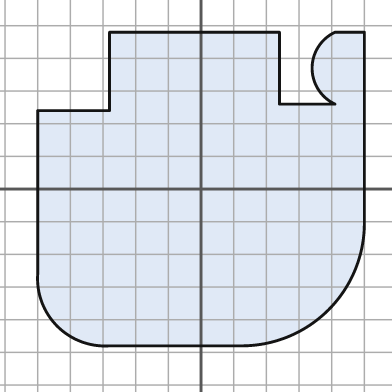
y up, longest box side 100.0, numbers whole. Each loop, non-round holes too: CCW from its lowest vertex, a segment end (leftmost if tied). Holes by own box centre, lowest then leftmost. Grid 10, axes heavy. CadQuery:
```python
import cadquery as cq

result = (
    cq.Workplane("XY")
    .moveTo(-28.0, -48.0)
    .lineTo(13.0, -48.0)
    .threePointArc((39.0, -37.0), (50.0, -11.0))
    .lineTo(50.0, 48.0)
    .lineTo(41.0, 48.0)
    .threePointArc((34.0, 37.0), (41.0, 26.0))
    .lineTo(24.0, 26.0)
    .lineTo(24.0, 48.0)
    .lineTo(-28.0, 48.0)
    .lineTo(-28.0, 24.0)
    .lineTo(-50.0, 24.0)
    .lineTo(-50.0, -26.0)
    .threePointArc((-44.0, -42.0), (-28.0, -48.0))
    .close()
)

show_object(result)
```